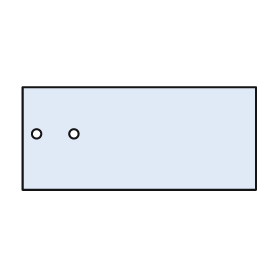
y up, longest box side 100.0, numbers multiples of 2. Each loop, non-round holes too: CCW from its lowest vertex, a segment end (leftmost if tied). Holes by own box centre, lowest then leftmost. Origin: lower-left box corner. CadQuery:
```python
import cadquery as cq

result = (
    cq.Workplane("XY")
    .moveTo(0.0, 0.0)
    .lineTo(100.0, 0.0)
    .lineTo(100.0, 44.0)
    .lineTo(0.0, 44.0)
    .close()
    .moveTo(6.0, 24.0)
    .circle(2.0)
    .moveTo(22.0, 24.0)
    .circle(2.0)
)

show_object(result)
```